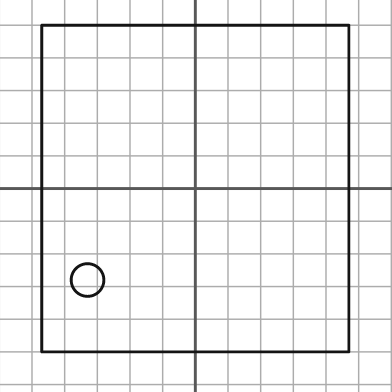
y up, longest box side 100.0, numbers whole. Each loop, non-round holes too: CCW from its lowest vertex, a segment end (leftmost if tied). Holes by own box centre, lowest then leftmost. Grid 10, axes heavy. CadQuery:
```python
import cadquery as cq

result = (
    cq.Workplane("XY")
    .moveTo(-47.0, -50.0)
    .lineTo(47.0, -50.0)
    .lineTo(47.0, 50.0)
    .lineTo(-47.0, 50.0)
    .close()
    .moveTo(-33.0, -28.0)
    .circle(5.0)
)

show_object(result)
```